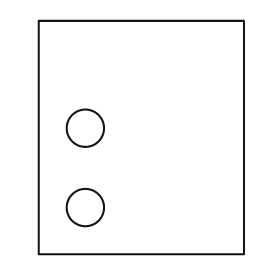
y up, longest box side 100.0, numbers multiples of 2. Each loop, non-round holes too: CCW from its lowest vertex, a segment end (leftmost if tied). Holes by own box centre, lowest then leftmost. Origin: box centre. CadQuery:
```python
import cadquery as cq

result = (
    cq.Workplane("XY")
    .moveTo(-44.0, -50.0)
    .lineTo(44.0, -50.0)
    .lineTo(44.0, 50.0)
    .lineTo(-44.0, 50.0)
    .close()
    .moveTo(-24.0, -30.0)
    .circle(8.0)
    .moveTo(-24.0, 4.0)
    .circle(8.0)
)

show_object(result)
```